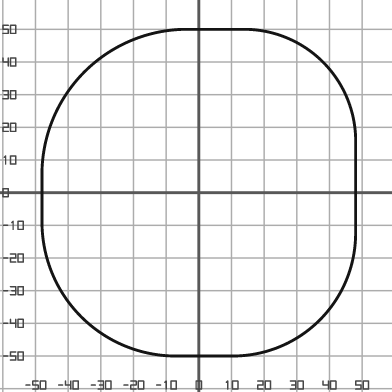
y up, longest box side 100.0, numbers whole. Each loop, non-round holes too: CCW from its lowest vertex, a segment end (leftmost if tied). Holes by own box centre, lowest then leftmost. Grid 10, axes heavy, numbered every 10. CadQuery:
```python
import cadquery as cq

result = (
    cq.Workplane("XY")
    .moveTo(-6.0, -50.0)
    .lineTo(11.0, -50.0)
    .threePointArc((37.0, -39.0), (48.0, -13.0))
    .lineTo(48.0, 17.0)
    .threePointArc((38.0, 40.0), (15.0, 50.0))
    .lineTo(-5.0, 50.0)
    .threePointArc((-35.0, 37.0), (-48.0, 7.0))
    .lineTo(-48.0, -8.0)
    .threePointArc((-36.0, -38.0), (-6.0, -50.0))
    .close()
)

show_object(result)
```